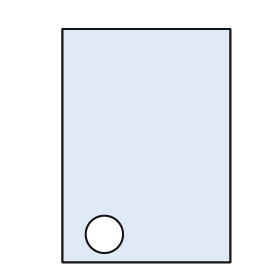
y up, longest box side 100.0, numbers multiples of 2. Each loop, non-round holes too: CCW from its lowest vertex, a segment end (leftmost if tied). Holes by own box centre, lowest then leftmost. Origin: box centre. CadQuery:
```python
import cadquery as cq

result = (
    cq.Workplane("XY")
    .moveTo(-36.0, -50.0)
    .lineTo(36.0, -50.0)
    .lineTo(36.0, 50.0)
    .lineTo(-36.0, 50.0)
    .close()
    .moveTo(-18.0, -38.0)
    .circle(8.0)
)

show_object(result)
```